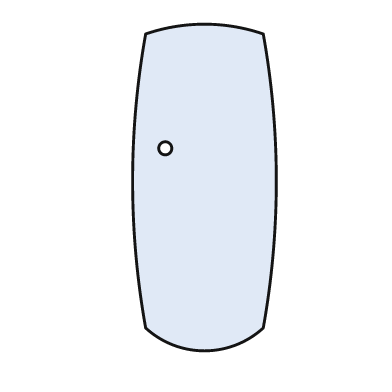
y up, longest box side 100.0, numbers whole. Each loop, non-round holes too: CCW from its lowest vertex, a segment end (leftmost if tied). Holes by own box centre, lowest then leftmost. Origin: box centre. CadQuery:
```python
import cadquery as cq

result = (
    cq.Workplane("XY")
    .moveTo(-18.0, -43.0)
    .threePointArc((0.0, -50.0), (18.0, -43.0))
    .threePointArc((22.0, 2.0), (18.0, 47.0))
    .threePointArc((0.0, 50.0), (-18.0, 47.0))
    .threePointArc((-22.0, 2.0), (-18.0, -43.0))
    .close()
    .moveTo(-12.0, 12.0)
    .circle(2.0)
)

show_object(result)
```